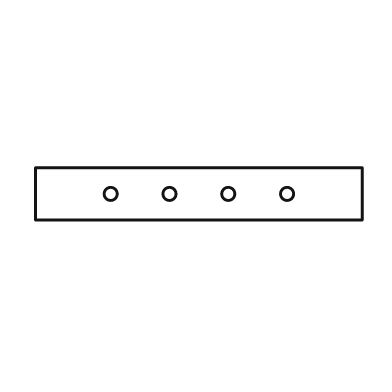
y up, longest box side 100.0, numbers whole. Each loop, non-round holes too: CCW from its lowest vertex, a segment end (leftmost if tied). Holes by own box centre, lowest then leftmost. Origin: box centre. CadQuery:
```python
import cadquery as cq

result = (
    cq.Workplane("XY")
    .moveTo(-50.0, -8.0)
    .lineTo(50.0, -8.0)
    .lineTo(50.0, 8.0)
    .lineTo(-50.0, 8.0)
    .close()
    .moveTo(-27.0, 0.0)
    .circle(2.0)
    .moveTo(-9.0, 0.0)
    .circle(2.0)
    .moveTo(9.0, 0.0)
    .circle(2.0)
    .moveTo(27.0, 0.0)
    .circle(2.0)
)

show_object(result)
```